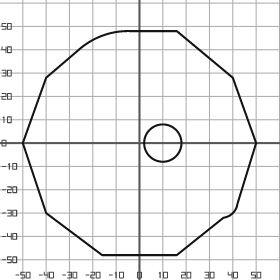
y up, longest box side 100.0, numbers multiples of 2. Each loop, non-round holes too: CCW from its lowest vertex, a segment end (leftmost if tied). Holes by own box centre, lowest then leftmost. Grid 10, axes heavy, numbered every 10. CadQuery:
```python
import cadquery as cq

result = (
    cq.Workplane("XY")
    .moveTo(-16.0, -48.0)
    .lineTo(16.0, -48.0)
    .lineTo(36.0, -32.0)
    .threePointArc((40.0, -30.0), (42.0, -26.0))
    .lineTo(50.0, 0.0)
    .lineTo(40.0, 28.0)
    .lineTo(16.0, 48.0)
    .lineTo(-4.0, 48.0)
    .threePointArc((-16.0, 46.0), (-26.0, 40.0))
    .lineTo(-40.0, 28.0)
    .lineTo(-50.0, 0.0)
    .lineTo(-40.0, -30.0)
    .close()
    .moveTo(10.0, 0.0)
    .circle(8.0)
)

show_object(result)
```